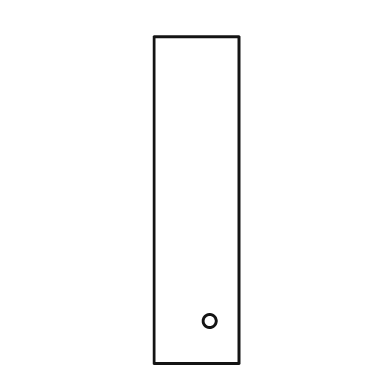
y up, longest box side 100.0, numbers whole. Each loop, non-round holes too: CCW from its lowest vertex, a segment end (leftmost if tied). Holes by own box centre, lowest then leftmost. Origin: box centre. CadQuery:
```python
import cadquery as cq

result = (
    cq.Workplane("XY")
    .moveTo(-13.0, -50.0)
    .lineTo(13.0, -50.0)
    .lineTo(13.0, 50.0)
    .lineTo(-13.0, 50.0)
    .close()
    .moveTo(4.0, -37.0)
    .circle(2.0)
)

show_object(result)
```